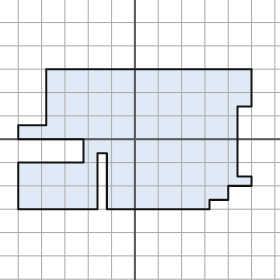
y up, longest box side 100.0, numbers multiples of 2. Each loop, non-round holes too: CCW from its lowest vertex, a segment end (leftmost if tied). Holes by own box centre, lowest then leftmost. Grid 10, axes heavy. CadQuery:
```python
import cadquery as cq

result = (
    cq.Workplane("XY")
    .moveTo(-50.0, -30.0)
    .lineTo(-16.0, -30.0)
    .lineTo(-16.0, -6.0)
    .lineTo(-12.0, -6.0)
    .lineTo(-12.0, -30.0)
    .lineTo(32.0, -30.0)
    .lineTo(32.0, -26.0)
    .lineTo(40.0, -26.0)
    .lineTo(40.0, -20.0)
    .lineTo(50.0, -20.0)
    .lineTo(50.0, -16.0)
    .lineTo(44.0, -16.0)
    .lineTo(44.0, 14.0)
    .lineTo(50.0, 14.0)
    .lineTo(50.0, 30.0)
    .lineTo(-38.0, 30.0)
    .lineTo(-38.0, 6.0)
    .lineTo(-50.0, 6.0)
    .lineTo(-50.0, 0.0)
    .lineTo(-22.0, 0.0)
    .lineTo(-22.0, -10.0)
    .lineTo(-50.0, -10.0)
    .close()
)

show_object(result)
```